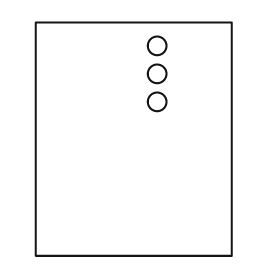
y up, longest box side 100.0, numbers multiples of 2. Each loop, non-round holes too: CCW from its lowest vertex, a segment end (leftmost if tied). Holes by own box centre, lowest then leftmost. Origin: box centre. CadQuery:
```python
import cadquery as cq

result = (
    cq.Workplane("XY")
    .moveTo(-42.0, -50.0)
    .lineTo(42.0, -50.0)
    .lineTo(42.0, 50.0)
    .lineTo(-42.0, 50.0)
    .close()
    .moveTo(10.0, 16.0)
    .circle(4.0)
    .moveTo(10.0, 28.0)
    .circle(4.0)
    .moveTo(10.0, 40.0)
    .circle(4.0)
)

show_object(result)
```